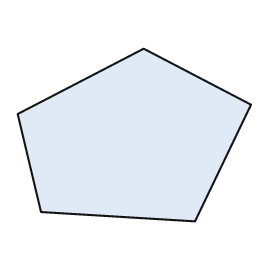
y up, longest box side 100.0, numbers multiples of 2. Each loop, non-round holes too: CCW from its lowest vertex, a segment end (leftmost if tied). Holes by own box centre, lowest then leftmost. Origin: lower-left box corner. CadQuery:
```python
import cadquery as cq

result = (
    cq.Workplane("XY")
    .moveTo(76.0, 0.0)
    .lineTo(100.0, 50.0)
    .lineTo(54.0, 74.0)
    .lineTo(0.0, 46.0)
    .lineTo(10.0, 4.0)
    .close()
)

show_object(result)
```